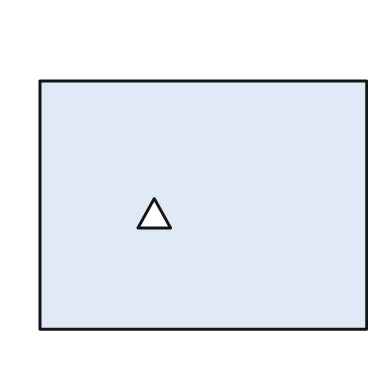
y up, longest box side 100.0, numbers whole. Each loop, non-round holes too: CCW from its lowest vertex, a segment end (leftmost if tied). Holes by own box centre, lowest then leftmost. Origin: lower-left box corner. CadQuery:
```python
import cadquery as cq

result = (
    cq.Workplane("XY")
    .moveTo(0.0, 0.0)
    .lineTo(100.0, 0.0)
    .lineTo(100.0, 76.0)
    .lineTo(0.0, 76.0)
    .close()
    .moveTo(30.0, 31.0)
    .lineTo(40.0, 31.0)
    .lineTo(35.0, 40.0)
    .close()
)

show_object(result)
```